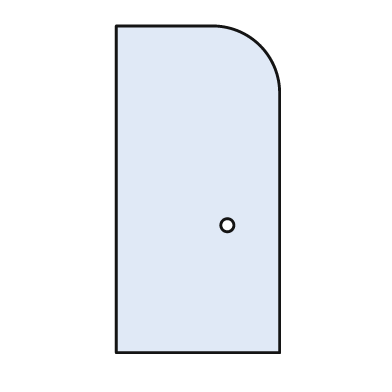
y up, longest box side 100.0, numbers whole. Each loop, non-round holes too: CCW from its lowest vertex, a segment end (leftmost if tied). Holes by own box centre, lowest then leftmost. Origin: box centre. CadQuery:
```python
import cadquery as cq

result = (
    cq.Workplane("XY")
    .moveTo(-25.0, -50.0)
    .lineTo(25.0, -50.0)
    .lineTo(25.0, 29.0)
    .threePointArc((19.0, 44.0), (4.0, 50.0))
    .lineTo(-25.0, 50.0)
    .close()
    .moveTo(9.0, -11.0)
    .circle(2.0)
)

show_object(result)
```